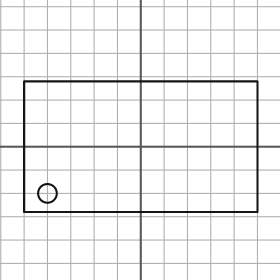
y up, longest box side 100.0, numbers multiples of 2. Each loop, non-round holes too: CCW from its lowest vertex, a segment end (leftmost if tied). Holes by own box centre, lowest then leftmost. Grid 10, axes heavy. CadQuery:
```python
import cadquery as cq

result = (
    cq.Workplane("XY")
    .moveTo(-50.0, -28.0)
    .lineTo(50.0, -28.0)
    .lineTo(50.0, 28.0)
    .lineTo(-50.0, 28.0)
    .close()
    .moveTo(-40.0, -20.0)
    .circle(4.0)
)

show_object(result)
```